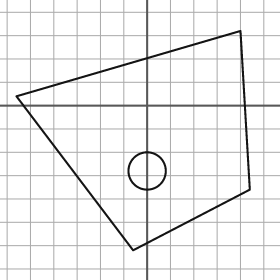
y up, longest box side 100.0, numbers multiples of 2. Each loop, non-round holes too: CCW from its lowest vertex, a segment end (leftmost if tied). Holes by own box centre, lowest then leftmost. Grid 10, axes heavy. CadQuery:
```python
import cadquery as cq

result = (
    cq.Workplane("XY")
    .moveTo(-6.0, -62.0)
    .lineTo(44.0, -36.0)
    .lineTo(40.0, 32.0)
    .lineTo(-56.0, 4.0)
    .close()
    .moveTo(0.0, -28.0)
    .circle(8.0)
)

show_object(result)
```